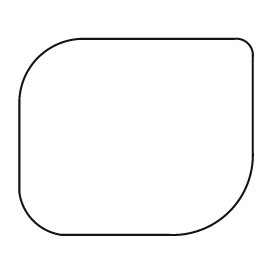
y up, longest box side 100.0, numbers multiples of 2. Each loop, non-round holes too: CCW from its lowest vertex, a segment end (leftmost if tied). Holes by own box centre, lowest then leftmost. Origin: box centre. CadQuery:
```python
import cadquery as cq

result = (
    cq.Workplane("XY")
    .moveTo(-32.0, -42.0)
    .lineTo(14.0, -42.0)
    .threePointArc((40.0, -32.0), (50.0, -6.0))
    .lineTo(50.0, 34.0)
    .threePointArc((48.0, 40.0), (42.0, 42.0))
    .lineTo(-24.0, 42.0)
    .threePointArc((-42.0, 34.0), (-50.0, 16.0))
    .lineTo(-50.0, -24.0)
    .threePointArc((-44.0, -36.0), (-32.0, -42.0))
    .close()
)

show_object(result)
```